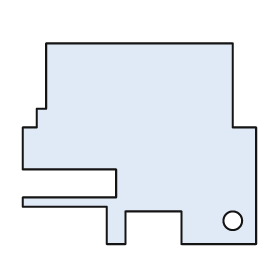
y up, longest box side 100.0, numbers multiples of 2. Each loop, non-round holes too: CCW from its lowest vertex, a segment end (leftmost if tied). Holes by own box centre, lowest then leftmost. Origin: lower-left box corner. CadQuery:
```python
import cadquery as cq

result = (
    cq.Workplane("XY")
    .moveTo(36.0, 0.0)
    .lineTo(44.0, 0.0)
    .lineTo(44.0, 14.0)
    .lineTo(68.0, 14.0)
    .lineTo(68.0, 0.0)
    .lineTo(100.0, 0.0)
    .lineTo(100.0, 50.0)
    .lineTo(90.0, 50.0)
    .lineTo(90.0, 86.0)
    .lineTo(10.0, 86.0)
    .lineTo(10.0, 58.0)
    .lineTo(6.0, 58.0)
    .lineTo(6.0, 50.0)
    .lineTo(0.0, 50.0)
    .lineTo(0.0, 32.0)
    .lineTo(40.0, 32.0)
    .lineTo(40.0, 20.0)
    .lineTo(0.0, 20.0)
    .lineTo(0.0, 16.0)
    .lineTo(36.0, 16.0)
    .close()
    .moveTo(90.0, 10.0)
    .circle(4.0)
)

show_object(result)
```